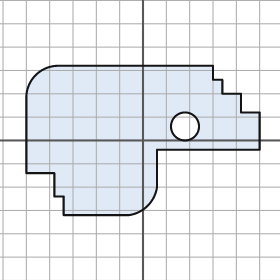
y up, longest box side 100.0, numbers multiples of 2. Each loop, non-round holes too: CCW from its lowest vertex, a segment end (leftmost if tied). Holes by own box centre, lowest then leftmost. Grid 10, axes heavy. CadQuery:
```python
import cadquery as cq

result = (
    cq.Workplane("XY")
    .moveTo(-34.0, -32.0)
    .lineTo(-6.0, -32.0)
    .threePointArc((2.0, -28.0), (6.0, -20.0))
    .lineTo(6.0, -4.0)
    .lineTo(50.0, -4.0)
    .lineTo(50.0, 12.0)
    .lineTo(42.0, 12.0)
    .lineTo(42.0, 20.0)
    .lineTo(34.0, 20.0)
    .lineTo(34.0, 26.0)
    .lineTo(30.0, 26.0)
    .lineTo(30.0, 32.0)
    .lineTo(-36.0, 32.0)
    .threePointArc((-46.0, 28.0), (-50.0, 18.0))
    .lineTo(-50.0, -14.0)
    .lineTo(-38.0, -14.0)
    .lineTo(-38.0, -24.0)
    .lineTo(-34.0, -24.0)
    .close()
    .moveTo(18.0, 6.0)
    .circle(6.0)
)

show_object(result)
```